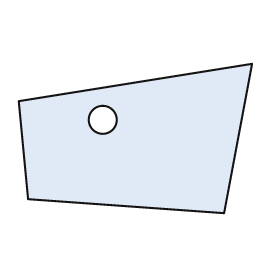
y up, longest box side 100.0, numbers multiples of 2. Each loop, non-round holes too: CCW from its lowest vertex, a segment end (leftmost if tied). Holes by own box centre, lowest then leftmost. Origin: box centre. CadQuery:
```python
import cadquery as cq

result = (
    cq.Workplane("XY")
    .moveTo(38.0, -32.0)
    .lineTo(50.0, 32.0)
    .lineTo(-50.0, 16.0)
    .lineTo(-46.0, -26.0)
    .close()
    .moveTo(-14.0, 8.0)
    .circle(6.0)
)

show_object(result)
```